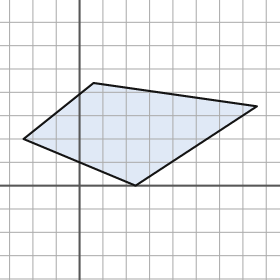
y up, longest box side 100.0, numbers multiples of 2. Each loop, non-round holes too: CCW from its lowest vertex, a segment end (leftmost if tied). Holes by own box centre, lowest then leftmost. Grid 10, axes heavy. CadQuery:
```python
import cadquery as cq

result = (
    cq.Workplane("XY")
    .moveTo(24.0, 0.0)
    .lineTo(76.0, 34.0)
    .lineTo(6.0, 44.0)
    .lineTo(-24.0, 20.0)
    .close()
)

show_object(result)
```